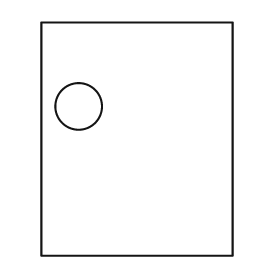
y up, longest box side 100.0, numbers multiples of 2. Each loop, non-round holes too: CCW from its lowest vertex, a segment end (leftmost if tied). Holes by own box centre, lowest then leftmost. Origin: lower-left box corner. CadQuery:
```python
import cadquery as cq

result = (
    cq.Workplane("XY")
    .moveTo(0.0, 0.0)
    .lineTo(82.0, 0.0)
    .lineTo(82.0, 100.0)
    .lineTo(0.0, 100.0)
    .close()
    .moveTo(16.0, 64.0)
    .circle(10.0)
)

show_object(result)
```